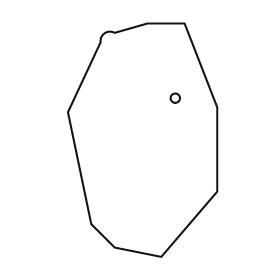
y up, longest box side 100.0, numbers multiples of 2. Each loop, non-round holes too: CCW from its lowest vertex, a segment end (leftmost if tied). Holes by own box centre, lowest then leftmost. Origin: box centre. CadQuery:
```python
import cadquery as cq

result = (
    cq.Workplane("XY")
    .moveTo(8.0, -50.0)
    .lineTo(32.0, -22.0)
    .lineTo(32.0, 14.0)
    .lineTo(18.0, 50.0)
    .lineTo(2.0, 50.0)
    .lineTo(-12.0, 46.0)
    .threePointArc((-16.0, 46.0), (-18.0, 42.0))
    .lineTo(-32.0, 12.0)
    .lineTo(-22.0, -36.0)
    .lineTo(-12.0, -46.0)
    .close()
    .moveTo(14.0, 18.0)
    .circle(2.0)
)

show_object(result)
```